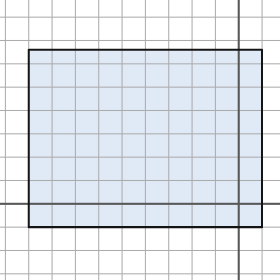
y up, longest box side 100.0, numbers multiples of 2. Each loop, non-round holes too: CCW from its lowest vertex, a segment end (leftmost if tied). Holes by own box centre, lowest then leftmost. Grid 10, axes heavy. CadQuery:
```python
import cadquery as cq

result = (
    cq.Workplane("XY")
    .moveTo(-90.0, -10.0)
    .lineTo(10.0, -10.0)
    .lineTo(10.0, 66.0)
    .lineTo(-90.0, 66.0)
    .close()
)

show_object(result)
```